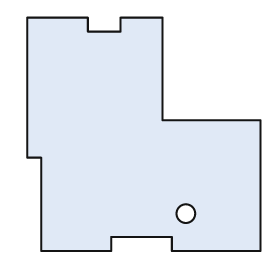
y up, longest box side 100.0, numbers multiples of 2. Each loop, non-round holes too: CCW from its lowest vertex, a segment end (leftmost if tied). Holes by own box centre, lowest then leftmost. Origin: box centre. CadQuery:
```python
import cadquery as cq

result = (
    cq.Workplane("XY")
    .moveTo(-44.0, -50.0)
    .lineTo(-14.0, -50.0)
    .lineTo(-14.0, -44.0)
    .lineTo(12.0, -44.0)
    .lineTo(12.0, -50.0)
    .lineTo(50.0, -50.0)
    .lineTo(50.0, 6.0)
    .lineTo(8.0, 6.0)
    .lineTo(8.0, 50.0)
    .lineTo(-10.0, 50.0)
    .lineTo(-10.0, 44.0)
    .lineTo(-24.0, 44.0)
    .lineTo(-24.0, 50.0)
    .lineTo(-50.0, 50.0)
    .lineTo(-50.0, -10.0)
    .lineTo(-44.0, -10.0)
    .close()
    .moveTo(18.0, -34.0)
    .circle(4.0)
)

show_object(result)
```